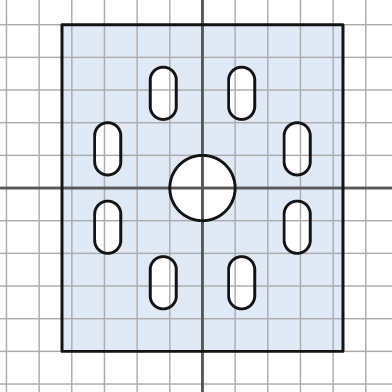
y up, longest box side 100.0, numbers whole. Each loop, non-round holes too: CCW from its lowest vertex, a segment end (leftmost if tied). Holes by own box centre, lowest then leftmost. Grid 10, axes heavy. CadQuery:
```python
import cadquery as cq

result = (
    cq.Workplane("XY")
    .moveTo(-43.0, -50.0)
    .lineTo(43.0, -50.0)
    .lineTo(43.0, 50.0)
    .lineTo(-43.0, 50.0)
    .close()
    .moveTo(-16.0, -33.0)
    .threePointArc((-12.0, -37.0), (-8.0, -33.0))
    .lineTo(-8.0, -25.0)
    .threePointArc((-12.0, -21.0), (-16.0, -25.0))
    .close()
    .moveTo(8.0, -33.0)
    .threePointArc((12.0, -37.0), (16.0, -33.0))
    .lineTo(16.0, -25.0)
    .threePointArc((12.0, -21.0), (8.0, -25.0))
    .close()
    .moveTo(-33.0, -16.0)
    .threePointArc((-29.0, -20.0), (-25.0, -16.0))
    .lineTo(-25.0, -8.0)
    .threePointArc((-29.0, -4.0), (-33.0, -8.0))
    .close()
    .moveTo(25.0, -16.0)
    .threePointArc((29.0, -20.0), (33.0, -16.0))
    .lineTo(33.0, -8.0)
    .threePointArc((29.0, -4.0), (25.0, -8.0))
    .close()
    .moveTo(0.0, 0.0)
    .circle(10.0)
    .moveTo(-33.0, 8.0)
    .threePointArc((-29.0, 4.0), (-25.0, 8.0))
    .lineTo(-25.0, 16.0)
    .threePointArc((-29.0, 20.0), (-33.0, 16.0))
    .close()
    .moveTo(25.0, 8.0)
    .threePointArc((29.0, 4.0), (33.0, 8.0))
    .lineTo(33.0, 16.0)
    .threePointArc((29.0, 20.0), (25.0, 16.0))
    .close()
    .moveTo(-16.0, 25.0)
    .threePointArc((-12.0, 21.0), (-8.0, 25.0))
    .lineTo(-8.0, 33.0)
    .threePointArc((-12.0, 37.0), (-16.0, 33.0))
    .close()
    .moveTo(8.0, 25.0)
    .threePointArc((12.0, 21.0), (16.0, 25.0))
    .lineTo(16.0, 33.0)
    .threePointArc((12.0, 37.0), (8.0, 33.0))
    .close()
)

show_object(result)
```